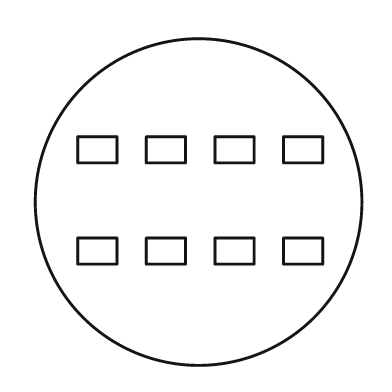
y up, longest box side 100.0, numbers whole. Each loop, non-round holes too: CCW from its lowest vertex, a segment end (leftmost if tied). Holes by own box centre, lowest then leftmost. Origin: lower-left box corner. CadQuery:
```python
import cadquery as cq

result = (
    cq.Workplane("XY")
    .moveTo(50.0, 50.0)
    .circle(50.0)
    .moveTo(13.0, 31.0)
    .lineTo(25.0, 31.0)
    .lineTo(25.0, 39.0)
    .lineTo(13.0, 39.0)
    .close()
    .moveTo(34.0, 31.0)
    .lineTo(46.0, 31.0)
    .lineTo(46.0, 39.0)
    .lineTo(34.0, 39.0)
    .close()
    .moveTo(55.0, 31.0)
    .lineTo(67.0, 31.0)
    .lineTo(67.0, 39.0)
    .lineTo(55.0, 39.0)
    .close()
    .moveTo(76.0, 31.0)
    .lineTo(88.0, 31.0)
    .lineTo(88.0, 39.0)
    .lineTo(76.0, 39.0)
    .close()
    .moveTo(13.0, 62.0)
    .lineTo(25.0, 62.0)
    .lineTo(25.0, 70.0)
    .lineTo(13.0, 70.0)
    .close()
    .moveTo(34.0, 62.0)
    .lineTo(46.0, 62.0)
    .lineTo(46.0, 70.0)
    .lineTo(34.0, 70.0)
    .close()
    .moveTo(55.0, 62.0)
    .lineTo(67.0, 62.0)
    .lineTo(67.0, 70.0)
    .lineTo(55.0, 70.0)
    .close()
    .moveTo(76.0, 62.0)
    .lineTo(88.0, 62.0)
    .lineTo(88.0, 70.0)
    .lineTo(76.0, 70.0)
    .close()
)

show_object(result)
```